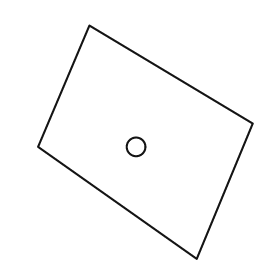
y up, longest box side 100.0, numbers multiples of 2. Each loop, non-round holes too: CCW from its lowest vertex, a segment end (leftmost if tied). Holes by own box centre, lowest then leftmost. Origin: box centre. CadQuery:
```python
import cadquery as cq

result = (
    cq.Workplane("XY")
    .moveTo(22.0, -50.0)
    .lineTo(46.0, 8.0)
    .lineTo(-24.0, 50.0)
    .lineTo(-46.0, -2.0)
    .close()
    .moveTo(-4.0, -2.0)
    .circle(4.0)
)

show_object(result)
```